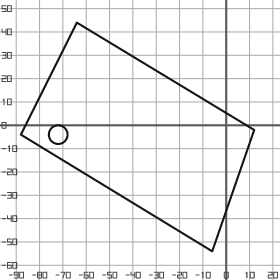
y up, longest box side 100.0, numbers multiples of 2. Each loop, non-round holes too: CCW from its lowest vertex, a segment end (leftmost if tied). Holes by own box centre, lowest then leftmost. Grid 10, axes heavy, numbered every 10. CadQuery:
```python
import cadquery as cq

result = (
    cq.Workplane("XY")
    .moveTo(-6.0, -54.0)
    .lineTo(12.0, -2.0)
    .lineTo(-64.0, 44.0)
    .lineTo(-88.0, -4.0)
    .close()
    .moveTo(-72.0, -4.0)
    .circle(4.0)
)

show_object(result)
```